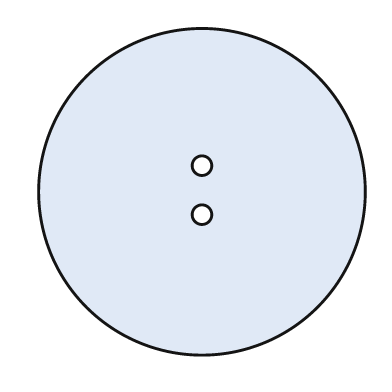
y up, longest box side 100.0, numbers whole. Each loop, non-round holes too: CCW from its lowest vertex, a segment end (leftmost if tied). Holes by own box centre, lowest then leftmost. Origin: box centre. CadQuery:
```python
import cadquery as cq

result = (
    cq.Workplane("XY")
    .moveTo(0.0, 0.0)
    .circle(50.0)
    .moveTo(0.0, -7.0)
    .circle(3.0)
    .moveTo(0.0, 8.0)
    .circle(3.0)
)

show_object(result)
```